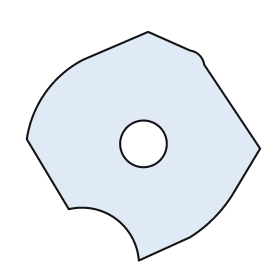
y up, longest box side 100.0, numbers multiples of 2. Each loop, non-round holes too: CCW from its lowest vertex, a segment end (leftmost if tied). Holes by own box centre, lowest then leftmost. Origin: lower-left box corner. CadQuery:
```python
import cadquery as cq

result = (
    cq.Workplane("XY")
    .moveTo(48.0, 0.0)
    .lineTo(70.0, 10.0)
    .threePointArc((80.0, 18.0), (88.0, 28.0))
    .lineTo(100.0, 48.0)
    .lineTo(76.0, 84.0)
    .threePointArc((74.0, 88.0), (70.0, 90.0))
    .lineTo(52.0, 98.0)
    .lineTo(24.0, 86.0)
    .threePointArc((8.0, 72.0), (0.0, 52.0))
    .lineTo(18.0, 22.0)
    .threePointArc((38.0, 18.0), (48.0, 0.0))
    .close()
    .moveTo(50.0, 50.0)
    .circle(10.0)
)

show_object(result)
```